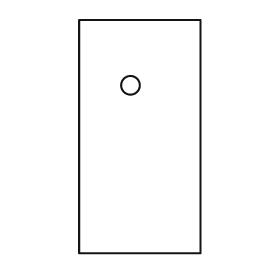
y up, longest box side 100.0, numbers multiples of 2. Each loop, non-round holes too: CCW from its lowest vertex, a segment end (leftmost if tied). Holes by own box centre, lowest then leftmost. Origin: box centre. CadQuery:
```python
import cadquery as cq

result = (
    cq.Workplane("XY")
    .moveTo(-26.0, -50.0)
    .lineTo(26.0, -50.0)
    .lineTo(26.0, 50.0)
    .lineTo(-26.0, 50.0)
    .close()
    .moveTo(-4.0, 22.0)
    .circle(4.0)
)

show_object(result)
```